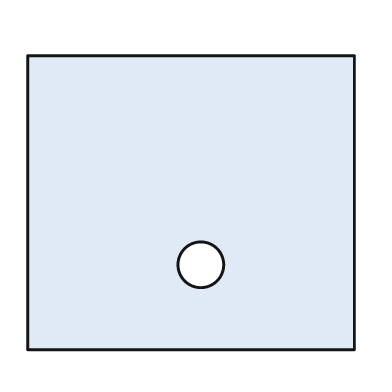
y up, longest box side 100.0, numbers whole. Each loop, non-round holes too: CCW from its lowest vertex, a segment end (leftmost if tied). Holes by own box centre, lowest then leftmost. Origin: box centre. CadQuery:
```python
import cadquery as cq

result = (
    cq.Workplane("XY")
    .moveTo(-50.0, -45.0)
    .lineTo(50.0, -45.0)
    .lineTo(50.0, 45.0)
    .lineTo(-50.0, 45.0)
    .close()
    .moveTo(3.0, -19.0)
    .circle(7.0)
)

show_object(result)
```